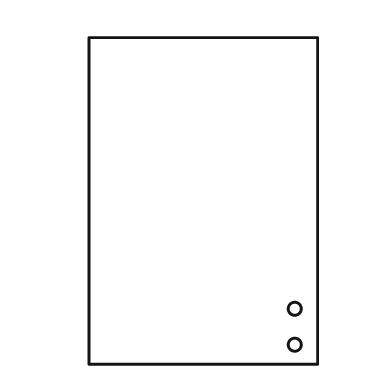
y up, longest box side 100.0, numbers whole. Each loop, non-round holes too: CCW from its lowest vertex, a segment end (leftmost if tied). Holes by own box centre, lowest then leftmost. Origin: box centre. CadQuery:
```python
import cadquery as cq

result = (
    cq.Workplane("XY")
    .moveTo(-35.0, -50.0)
    .lineTo(35.0, -50.0)
    .lineTo(35.0, 50.0)
    .lineTo(-35.0, 50.0)
    .close()
    .moveTo(28.0, -44.0)
    .circle(2.0)
    .moveTo(28.0, -33.0)
    .circle(2.0)
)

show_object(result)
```